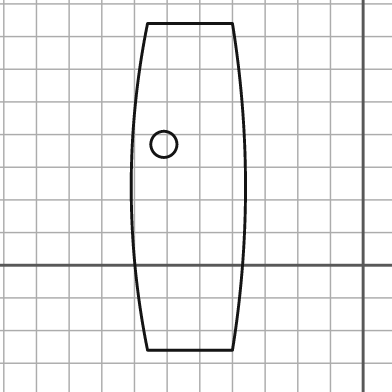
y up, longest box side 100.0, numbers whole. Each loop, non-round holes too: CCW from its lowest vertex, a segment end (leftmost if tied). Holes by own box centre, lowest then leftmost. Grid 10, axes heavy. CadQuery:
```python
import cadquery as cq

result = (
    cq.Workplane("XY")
    .moveTo(-66.0, -26.0)
    .lineTo(-40.0, -26.0)
    .threePointArc((-36.0, 24.0), (-40.0, 74.0))
    .lineTo(-66.0, 74.0)
    .threePointArc((-71.0, 24.0), (-66.0, -26.0))
    .close()
    .moveTo(-61.0, 37.0)
    .circle(4.0)
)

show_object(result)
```